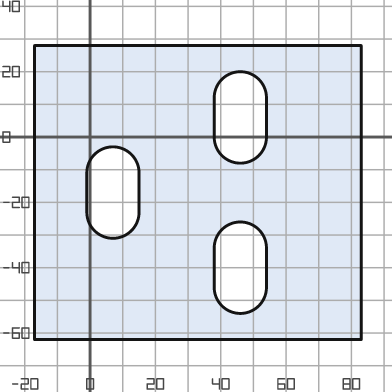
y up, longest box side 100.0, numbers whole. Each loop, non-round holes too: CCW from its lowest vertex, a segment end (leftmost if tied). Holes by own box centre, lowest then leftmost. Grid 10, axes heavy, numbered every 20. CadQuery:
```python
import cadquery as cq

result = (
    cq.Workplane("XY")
    .moveTo(-17.0, -62.0)
    .lineTo(83.0, -62.0)
    .lineTo(83.0, 28.0)
    .lineTo(-17.0, 28.0)
    .close()
    .moveTo(38.0, -46.0)
    .threePointArc((46.0, -54.0), (54.0, -46.0))
    .lineTo(54.0, -34.0)
    .threePointArc((46.0, -26.0), (38.0, -34.0))
    .close()
    .moveTo(-1.0, -23.0)
    .threePointArc((7.0, -31.0), (15.0, -23.0))
    .lineTo(15.0, -11.0)
    .threePointArc((7.0, -3.0), (-1.0, -11.0))
    .close()
    .moveTo(38.0, 0.0)
    .threePointArc((46.0, -8.0), (54.0, 0.0))
    .lineTo(54.0, 12.0)
    .threePointArc((46.0, 20.0), (38.0, 12.0))
    .close()
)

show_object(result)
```